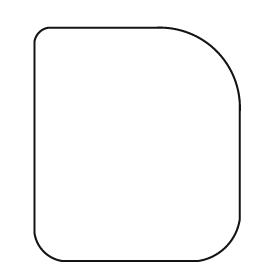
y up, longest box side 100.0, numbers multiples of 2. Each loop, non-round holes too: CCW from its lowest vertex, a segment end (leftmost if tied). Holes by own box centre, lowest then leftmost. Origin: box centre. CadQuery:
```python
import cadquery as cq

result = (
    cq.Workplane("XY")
    .moveTo(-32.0, -50.0)
    .lineTo(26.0, -50.0)
    .threePointArc((38.0, -44.0), (44.0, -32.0))
    .lineTo(44.0, 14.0)
    .threePointArc((34.0, 40.0), (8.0, 50.0))
    .lineTo(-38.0, 50.0)
    .threePointArc((-42.0, 48.0), (-44.0, 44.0))
    .lineTo(-44.0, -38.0)
    .threePointArc((-40.0, -46.0), (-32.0, -50.0))
    .close()
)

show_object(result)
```